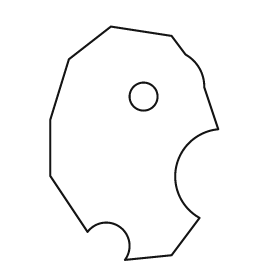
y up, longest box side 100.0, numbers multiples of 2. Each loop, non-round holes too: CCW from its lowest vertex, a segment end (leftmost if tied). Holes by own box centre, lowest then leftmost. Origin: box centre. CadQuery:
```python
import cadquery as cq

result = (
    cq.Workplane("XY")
    .moveTo(-4.0, -50.0)
    .lineTo(16.0, -48.0)
    .lineTo(28.0, -32.0)
    .threePointArc((18.0, -10.0), (36.0, 6.0))
    .lineTo(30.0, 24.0)
    .threePointArc((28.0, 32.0), (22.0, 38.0))
    .lineTo(16.0, 46.0)
    .lineTo(-10.0, 50.0)
    .lineTo(-28.0, 36.0)
    .lineTo(-36.0, 10.0)
    .lineTo(-36.0, -14.0)
    .lineTo(-20.0, -38.0)
    .threePointArc((-6.0, -36.0), (-4.0, -50.0))
    .close()
    .moveTo(4.0, 20.0)
    .circle(6.0)
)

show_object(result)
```